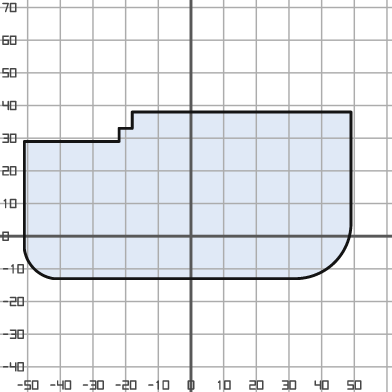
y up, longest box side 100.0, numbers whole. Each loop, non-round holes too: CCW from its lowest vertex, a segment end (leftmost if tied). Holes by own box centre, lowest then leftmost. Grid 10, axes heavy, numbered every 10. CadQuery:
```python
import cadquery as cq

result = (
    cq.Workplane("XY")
    .moveTo(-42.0, -13.0)
    .lineTo(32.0, -13.0)
    .threePointArc((44.0, -8.0), (49.0, 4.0))
    .lineTo(49.0, 38.0)
    .lineTo(-18.0, 38.0)
    .lineTo(-18.0, 33.0)
    .lineTo(-22.0, 33.0)
    .lineTo(-22.0, 29.0)
    .lineTo(-51.0, 29.0)
    .lineTo(-51.0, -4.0)
    .threePointArc((-48.0, -10.0), (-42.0, -13.0))
    .close()
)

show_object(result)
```